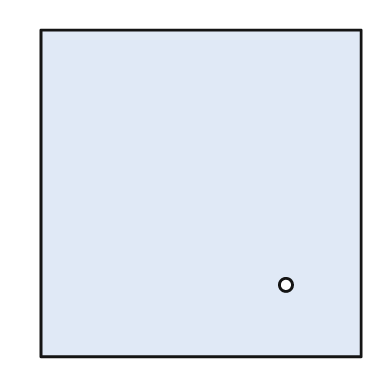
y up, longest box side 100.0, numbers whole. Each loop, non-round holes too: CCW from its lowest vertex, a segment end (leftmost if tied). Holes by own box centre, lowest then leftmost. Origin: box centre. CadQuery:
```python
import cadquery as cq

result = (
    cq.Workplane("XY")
    .moveTo(-49.0, -50.0)
    .lineTo(49.0, -50.0)
    .lineTo(49.0, 50.0)
    .lineTo(-49.0, 50.0)
    .close()
    .moveTo(26.0, -28.0)
    .circle(2.0)
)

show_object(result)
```